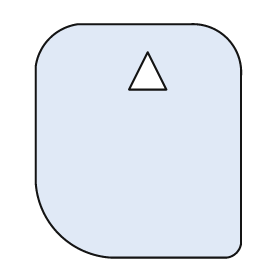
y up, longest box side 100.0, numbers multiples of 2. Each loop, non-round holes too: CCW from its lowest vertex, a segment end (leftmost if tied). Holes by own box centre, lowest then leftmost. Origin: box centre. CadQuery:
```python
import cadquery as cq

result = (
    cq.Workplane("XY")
    .moveTo(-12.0, -50.0)
    .lineTo(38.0, -50.0)
    .threePointArc((42.0, -48.0), (44.0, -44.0))
    .lineTo(44.0, 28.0)
    .threePointArc((38.0, 44.0), (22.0, 50.0))
    .lineTo(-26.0, 50.0)
    .threePointArc((-38.0, 44.0), (-44.0, 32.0))
    .lineTo(-44.0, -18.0)
    .threePointArc((-34.0, -40.0), (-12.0, -50.0))
    .close()
    .moveTo(-4.0, 22.0)
    .lineTo(12.0, 22.0)
    .lineTo(4.0, 38.0)
    .close()
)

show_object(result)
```